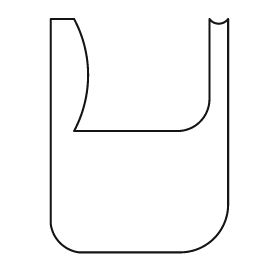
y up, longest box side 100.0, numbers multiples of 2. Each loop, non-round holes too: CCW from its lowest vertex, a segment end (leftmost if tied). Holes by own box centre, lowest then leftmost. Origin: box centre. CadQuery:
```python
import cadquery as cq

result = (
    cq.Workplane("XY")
    .moveTo(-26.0, -50.0)
    .lineTo(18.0, -50.0)
    .threePointArc((32.0, -44.0), (38.0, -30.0))
    .lineTo(38.0, 50.0)
    .threePointArc((34.0, 48.0), (30.0, 50.0))
    .lineTo(30.0, 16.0)
    .threePointArc((26.0, 6.0), (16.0, 2.0))
    .lineTo(-28.0, 2.0)
    .threePointArc((-22.0, 26.0), (-28.0, 50.0))
    .lineTo(-38.0, 50.0)
    .lineTo(-38.0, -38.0)
    .threePointArc((-34.0, -46.0), (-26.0, -50.0))
    .close()
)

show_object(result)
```